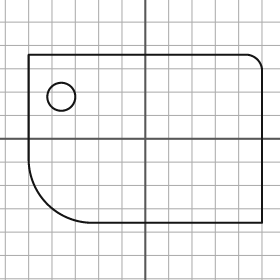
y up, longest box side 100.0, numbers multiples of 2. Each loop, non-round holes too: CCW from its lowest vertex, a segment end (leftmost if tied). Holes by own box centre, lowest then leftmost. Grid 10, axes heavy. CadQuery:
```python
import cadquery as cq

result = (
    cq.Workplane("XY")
    .moveTo(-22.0, -36.0)
    .lineTo(50.0, -36.0)
    .lineTo(50.0, 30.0)
    .threePointArc((48.0, 34.0), (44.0, 36.0))
    .lineTo(-50.0, 36.0)
    .lineTo(-50.0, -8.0)
    .threePointArc((-42.0, -28.0), (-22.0, -36.0))
    .close()
    .moveTo(-36.0, 18.0)
    .circle(6.0)
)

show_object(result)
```